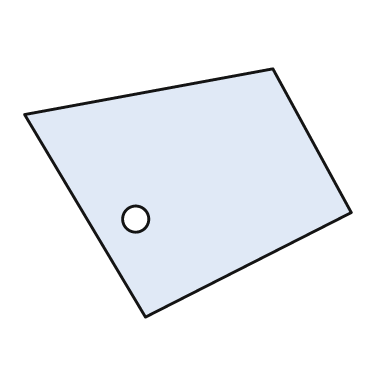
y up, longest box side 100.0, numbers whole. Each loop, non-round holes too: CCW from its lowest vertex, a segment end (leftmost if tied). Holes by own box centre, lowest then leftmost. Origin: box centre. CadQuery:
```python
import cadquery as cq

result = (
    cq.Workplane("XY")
    .moveTo(-13.0, -38.0)
    .lineTo(50.0, -6.0)
    .lineTo(26.0, 38.0)
    .lineTo(-50.0, 24.0)
    .close()
    .moveTo(-16.0, -8.0)
    .circle(4.0)
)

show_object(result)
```